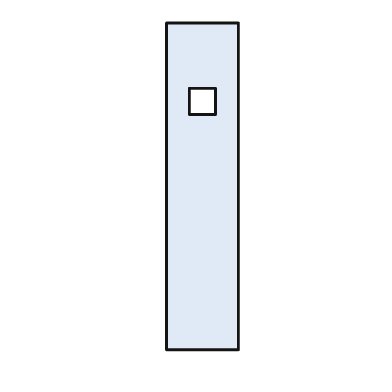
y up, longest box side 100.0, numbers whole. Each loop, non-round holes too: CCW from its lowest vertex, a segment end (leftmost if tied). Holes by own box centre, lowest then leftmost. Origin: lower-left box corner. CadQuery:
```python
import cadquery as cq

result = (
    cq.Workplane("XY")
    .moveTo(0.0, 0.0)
    .lineTo(22.0, 0.0)
    .lineTo(22.0, 100.0)
    .lineTo(0.0, 100.0)
    .close()
    .moveTo(7.0, 72.0)
    .lineTo(15.0, 72.0)
    .lineTo(15.0, 80.0)
    .lineTo(7.0, 80.0)
    .close()
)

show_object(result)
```